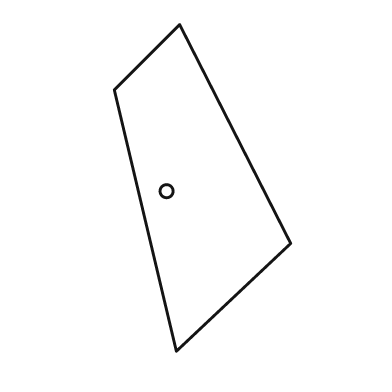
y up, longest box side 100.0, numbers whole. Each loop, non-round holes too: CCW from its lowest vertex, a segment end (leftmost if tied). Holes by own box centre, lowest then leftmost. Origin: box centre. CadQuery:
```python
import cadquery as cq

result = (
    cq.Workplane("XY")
    .moveTo(-8.0, -50.0)
    .lineTo(27.0, -17.0)
    .lineTo(-7.0, 50.0)
    .lineTo(-27.0, 30.0)
    .close()
    .moveTo(-11.0, -1.0)
    .circle(2.0)
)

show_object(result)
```